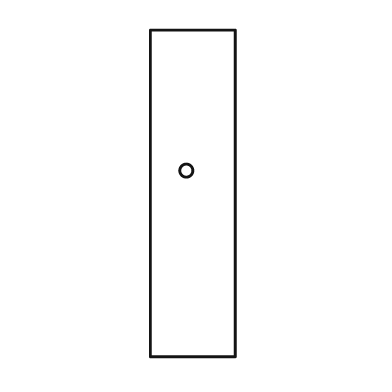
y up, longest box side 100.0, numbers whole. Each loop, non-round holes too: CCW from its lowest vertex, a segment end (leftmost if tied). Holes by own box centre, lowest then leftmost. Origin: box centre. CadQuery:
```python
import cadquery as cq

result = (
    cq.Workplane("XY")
    .moveTo(-13.0, -50.0)
    .lineTo(13.0, -50.0)
    .lineTo(13.0, 50.0)
    .lineTo(-13.0, 50.0)
    .close()
    .moveTo(-2.0, 7.0)
    .circle(2.0)
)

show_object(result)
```